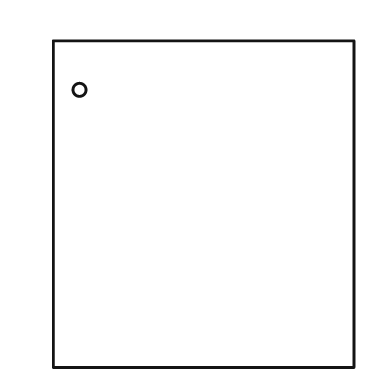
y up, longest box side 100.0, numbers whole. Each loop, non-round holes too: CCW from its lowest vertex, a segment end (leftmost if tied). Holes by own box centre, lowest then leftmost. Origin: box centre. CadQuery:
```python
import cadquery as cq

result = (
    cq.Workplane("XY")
    .moveTo(-46.0, -50.0)
    .lineTo(46.0, -50.0)
    .lineTo(46.0, 50.0)
    .lineTo(-46.0, 50.0)
    .close()
    .moveTo(-38.0, 35.0)
    .circle(2.0)
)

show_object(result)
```